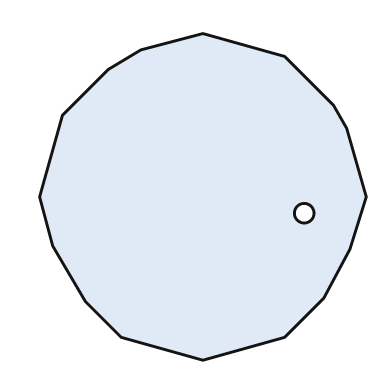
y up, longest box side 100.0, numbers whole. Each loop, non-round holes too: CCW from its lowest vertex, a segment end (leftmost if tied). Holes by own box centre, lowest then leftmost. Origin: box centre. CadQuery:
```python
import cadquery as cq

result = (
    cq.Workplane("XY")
    .moveTo(0.0, -50.0)
    .lineTo(25.0, -43.0)
    .lineTo(37.0, -31.0)
    .lineTo(45.0, -16.0)
    .lineTo(50.0, 0.0)
    .lineTo(44.0, 21.0)
    .lineTo(40.0, 28.0)
    .lineTo(25.0, 43.0)
    .lineTo(0.0, 50.0)
    .lineTo(-19.0, 45.0)
    .lineTo(-29.0, 39.0)
    .lineTo(-43.0, 25.0)
    .lineTo(-50.0, 0.0)
    .lineTo(-46.0, -15.0)
    .lineTo(-36.0, -32.0)
    .lineTo(-25.0, -43.0)
    .close()
    .moveTo(31.0, -5.0)
    .circle(3.0)
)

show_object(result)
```